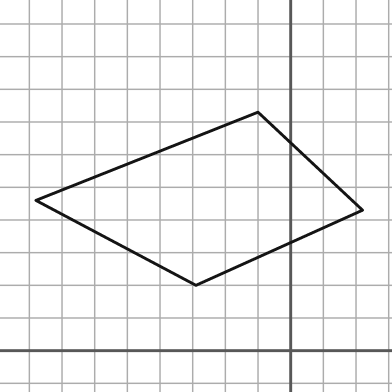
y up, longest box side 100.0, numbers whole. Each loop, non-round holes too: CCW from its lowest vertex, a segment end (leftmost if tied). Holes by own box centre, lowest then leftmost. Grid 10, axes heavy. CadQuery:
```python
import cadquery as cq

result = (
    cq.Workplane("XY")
    .moveTo(-29.0, 20.0)
    .lineTo(22.0, 43.0)
    .lineTo(-10.0, 73.0)
    .lineTo(-78.0, 46.0)
    .close()
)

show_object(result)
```